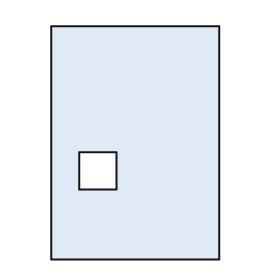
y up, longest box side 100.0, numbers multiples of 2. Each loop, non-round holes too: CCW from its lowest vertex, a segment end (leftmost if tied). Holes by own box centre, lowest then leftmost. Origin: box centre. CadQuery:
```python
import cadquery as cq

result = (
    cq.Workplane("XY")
    .moveTo(-36.0, -50.0)
    .lineTo(36.0, -50.0)
    .lineTo(36.0, 50.0)
    .lineTo(-36.0, 50.0)
    .close()
    .moveTo(-24.0, -20.0)
    .lineTo(-8.0, -20.0)
    .lineTo(-8.0, -4.0)
    .lineTo(-24.0, -4.0)
    .close()
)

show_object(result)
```